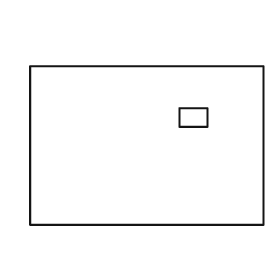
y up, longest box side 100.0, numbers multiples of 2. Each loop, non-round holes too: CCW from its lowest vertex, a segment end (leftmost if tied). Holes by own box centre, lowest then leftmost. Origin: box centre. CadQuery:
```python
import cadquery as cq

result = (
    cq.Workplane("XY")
    .moveTo(-50.0, -34.0)
    .lineTo(50.0, -34.0)
    .lineTo(50.0, 34.0)
    .lineTo(-50.0, 34.0)
    .close()
    .moveTo(14.0, 8.0)
    .lineTo(26.0, 8.0)
    .lineTo(26.0, 16.0)
    .lineTo(14.0, 16.0)
    .close()
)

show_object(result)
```